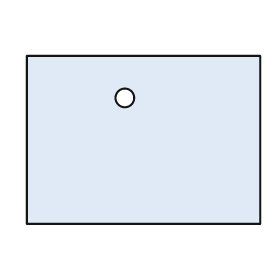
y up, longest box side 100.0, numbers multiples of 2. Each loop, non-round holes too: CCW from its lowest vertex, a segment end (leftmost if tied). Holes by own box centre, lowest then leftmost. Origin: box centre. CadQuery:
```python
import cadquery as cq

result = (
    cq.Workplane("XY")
    .moveTo(-50.0, -36.0)
    .lineTo(50.0, -36.0)
    .lineTo(50.0, 36.0)
    .lineTo(-50.0, 36.0)
    .close()
    .moveTo(-8.0, 18.0)
    .circle(4.0)
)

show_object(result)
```